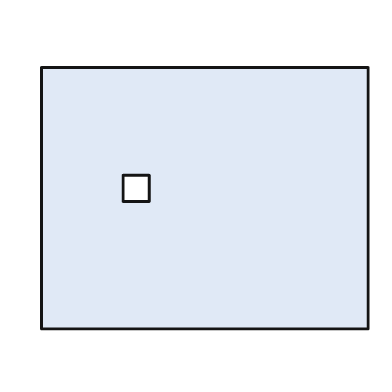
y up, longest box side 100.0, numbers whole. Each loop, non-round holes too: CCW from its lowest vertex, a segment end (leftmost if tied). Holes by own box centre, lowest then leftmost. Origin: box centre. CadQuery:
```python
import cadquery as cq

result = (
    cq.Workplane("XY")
    .moveTo(-50.0, -40.0)
    .lineTo(50.0, -40.0)
    .lineTo(50.0, 40.0)
    .lineTo(-50.0, 40.0)
    .close()
    .moveTo(-25.0, -1.0)
    .lineTo(-17.0, -1.0)
    .lineTo(-17.0, 7.0)
    .lineTo(-25.0, 7.0)
    .close()
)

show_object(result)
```